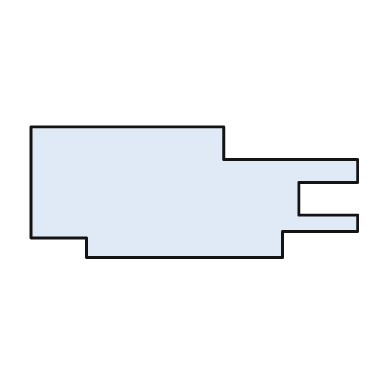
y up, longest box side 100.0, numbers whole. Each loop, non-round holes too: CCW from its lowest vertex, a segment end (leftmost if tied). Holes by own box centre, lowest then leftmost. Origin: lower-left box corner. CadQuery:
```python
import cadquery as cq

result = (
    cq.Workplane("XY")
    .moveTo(17.0, 0.0)
    .lineTo(77.0, 0.0)
    .lineTo(77.0, 8.0)
    .lineTo(100.0, 8.0)
    .lineTo(100.0, 13.0)
    .lineTo(82.0, 13.0)
    .lineTo(82.0, 23.0)
    .lineTo(100.0, 23.0)
    .lineTo(100.0, 30.0)
    .lineTo(59.0, 30.0)
    .lineTo(59.0, 40.0)
    .lineTo(0.0, 40.0)
    .lineTo(0.0, 6.0)
    .lineTo(17.0, 6.0)
    .close()
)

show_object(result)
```